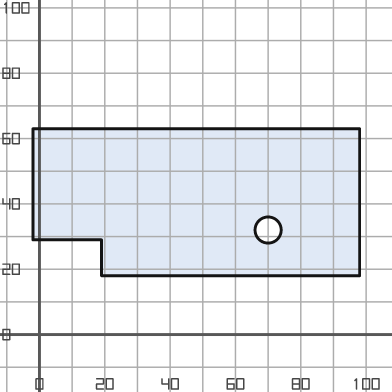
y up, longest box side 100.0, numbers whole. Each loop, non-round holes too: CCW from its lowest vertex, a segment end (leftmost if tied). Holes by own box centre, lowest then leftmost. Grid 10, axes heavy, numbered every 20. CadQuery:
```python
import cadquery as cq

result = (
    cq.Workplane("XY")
    .moveTo(19.0, 18.0)
    .lineTo(98.0, 18.0)
    .lineTo(98.0, 63.0)
    .lineTo(-2.0, 63.0)
    .lineTo(-2.0, 29.0)
    .lineTo(19.0, 29.0)
    .close()
    .moveTo(70.0, 32.0)
    .circle(4.0)
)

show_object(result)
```